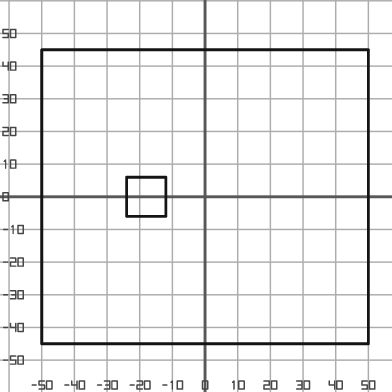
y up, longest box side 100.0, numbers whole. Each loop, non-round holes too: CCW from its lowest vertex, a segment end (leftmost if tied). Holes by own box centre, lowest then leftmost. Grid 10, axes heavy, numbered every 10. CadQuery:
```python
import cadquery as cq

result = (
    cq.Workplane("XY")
    .moveTo(-50.0, -45.0)
    .lineTo(50.0, -45.0)
    .lineTo(50.0, 45.0)
    .lineTo(-50.0, 45.0)
    .close()
    .moveTo(-24.0, -6.0)
    .lineTo(-12.0, -6.0)
    .lineTo(-12.0, 6.0)
    .lineTo(-24.0, 6.0)
    .close()
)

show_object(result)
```